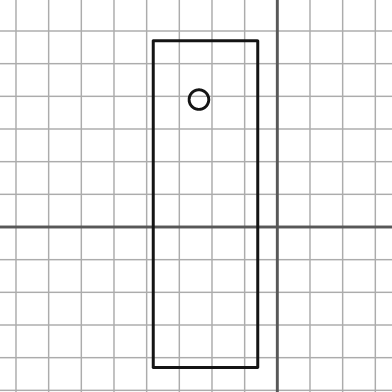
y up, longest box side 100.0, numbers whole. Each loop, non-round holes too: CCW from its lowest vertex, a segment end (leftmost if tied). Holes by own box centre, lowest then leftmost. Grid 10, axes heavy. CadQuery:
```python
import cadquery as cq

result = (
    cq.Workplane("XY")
    .moveTo(-38.0, -43.0)
    .lineTo(-6.0, -43.0)
    .lineTo(-6.0, 57.0)
    .lineTo(-38.0, 57.0)
    .close()
    .moveTo(-24.0, 39.0)
    .circle(3.0)
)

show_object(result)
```